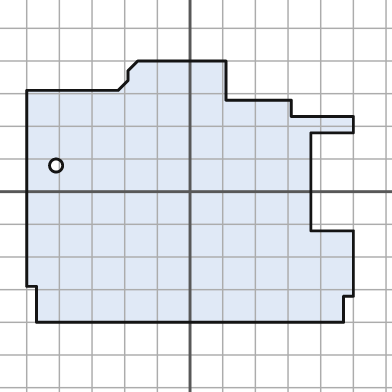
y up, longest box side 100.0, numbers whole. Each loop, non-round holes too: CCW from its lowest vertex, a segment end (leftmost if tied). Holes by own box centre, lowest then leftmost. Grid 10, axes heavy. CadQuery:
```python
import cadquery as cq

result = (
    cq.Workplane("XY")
    .moveTo(-47.0, -40.0)
    .lineTo(47.0, -40.0)
    .lineTo(47.0, -32.0)
    .lineTo(50.0, -32.0)
    .lineTo(50.0, -12.0)
    .lineTo(37.0, -12.0)
    .lineTo(37.0, 18.0)
    .lineTo(50.0, 18.0)
    .lineTo(50.0, 23.0)
    .lineTo(31.0, 23.0)
    .lineTo(31.0, 28.0)
    .lineTo(11.0, 28.0)
    .lineTo(11.0, 40.0)
    .lineTo(-16.0, 40.0)
    .lineTo(-19.0, 37.0)
    .lineTo(-19.0, 34.0)
    .lineTo(-22.0, 31.0)
    .lineTo(-50.0, 31.0)
    .lineTo(-50.0, -29.0)
    .lineTo(-47.0, -29.0)
    .close()
    .moveTo(-41.0, 8.0)
    .circle(2.0)
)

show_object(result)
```